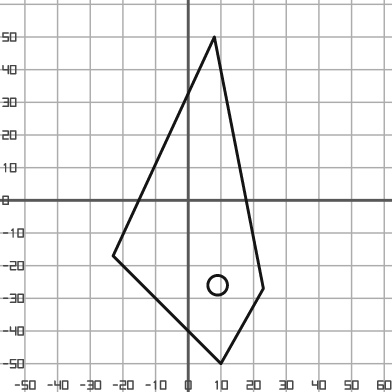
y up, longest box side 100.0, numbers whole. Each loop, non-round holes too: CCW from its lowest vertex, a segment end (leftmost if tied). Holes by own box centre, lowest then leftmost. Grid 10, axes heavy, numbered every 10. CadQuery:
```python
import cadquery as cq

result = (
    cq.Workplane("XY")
    .moveTo(10.0, -50.0)
    .lineTo(23.0, -27.0)
    .lineTo(8.0, 50.0)
    .lineTo(-23.0, -17.0)
    .close()
    .moveTo(9.0, -26.0)
    .circle(3.0)
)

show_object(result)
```